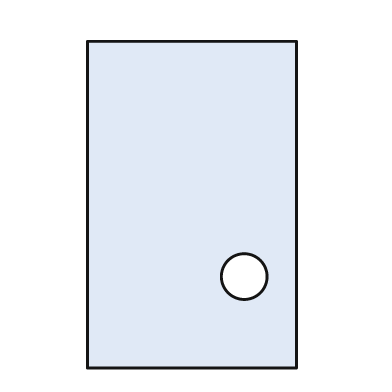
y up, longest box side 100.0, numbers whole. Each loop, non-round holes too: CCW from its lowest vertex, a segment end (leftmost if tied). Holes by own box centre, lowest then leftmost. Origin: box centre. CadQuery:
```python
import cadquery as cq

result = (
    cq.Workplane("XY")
    .moveTo(-32.0, -50.0)
    .lineTo(32.0, -50.0)
    .lineTo(32.0, 50.0)
    .lineTo(-32.0, 50.0)
    .close()
    .moveTo(16.0, -22.0)
    .circle(7.0)
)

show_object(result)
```